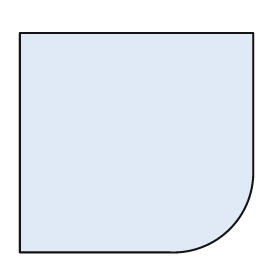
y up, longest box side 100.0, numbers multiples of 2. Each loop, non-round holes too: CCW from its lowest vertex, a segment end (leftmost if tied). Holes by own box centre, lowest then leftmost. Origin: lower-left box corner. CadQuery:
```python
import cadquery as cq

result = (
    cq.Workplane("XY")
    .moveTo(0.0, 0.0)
    .lineTo(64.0, 0.0)
    .threePointArc((90.0, 10.0), (100.0, 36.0))
    .lineTo(100.0, 94.0)
    .lineTo(0.0, 94.0)
    .close()
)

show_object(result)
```